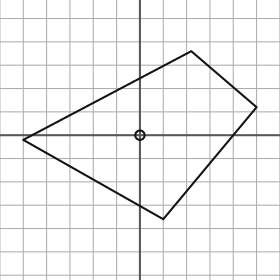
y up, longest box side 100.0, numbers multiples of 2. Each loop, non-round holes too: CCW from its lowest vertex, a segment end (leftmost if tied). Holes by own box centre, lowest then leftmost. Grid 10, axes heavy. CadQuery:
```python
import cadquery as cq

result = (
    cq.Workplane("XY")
    .moveTo(10.0, -36.0)
    .lineTo(50.0, 12.0)
    .lineTo(22.0, 36.0)
    .lineTo(-50.0, -2.0)
    .close()
    .moveTo(0.0, 0.0)
    .circle(2.0)
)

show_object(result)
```